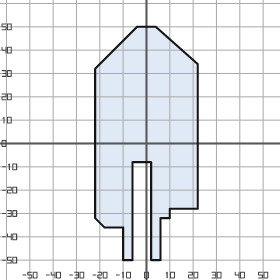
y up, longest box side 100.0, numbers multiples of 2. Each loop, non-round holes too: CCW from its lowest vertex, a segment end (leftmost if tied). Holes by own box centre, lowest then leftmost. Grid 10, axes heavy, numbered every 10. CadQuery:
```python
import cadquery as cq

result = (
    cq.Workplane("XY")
    .moveTo(-10.0, -50.0)
    .lineTo(-6.0, -50.0)
    .lineTo(-6.0, -8.0)
    .lineTo(2.0, -8.0)
    .lineTo(2.0, -50.0)
    .lineTo(6.0, -50.0)
    .lineTo(6.0, -32.0)
    .lineTo(10.0, -32.0)
    .lineTo(10.0, -28.0)
    .lineTo(22.0, -28.0)
    .lineTo(22.0, 34.0)
    .lineTo(4.0, 50.0)
    .lineTo(-4.0, 50.0)
    .lineTo(-22.0, 32.0)
    .lineTo(-22.0, -32.0)
    .lineTo(-18.0, -36.0)
    .lineTo(-10.0, -36.0)
    .close()
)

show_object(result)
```